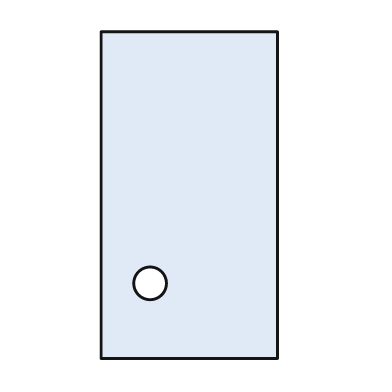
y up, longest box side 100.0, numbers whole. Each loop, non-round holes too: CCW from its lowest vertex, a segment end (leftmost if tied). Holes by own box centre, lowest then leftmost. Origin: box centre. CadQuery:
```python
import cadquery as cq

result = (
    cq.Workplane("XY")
    .moveTo(-27.0, -50.0)
    .lineTo(27.0, -50.0)
    .lineTo(27.0, 50.0)
    .lineTo(-27.0, 50.0)
    .close()
    .moveTo(-12.0, -27.0)
    .circle(5.0)
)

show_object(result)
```